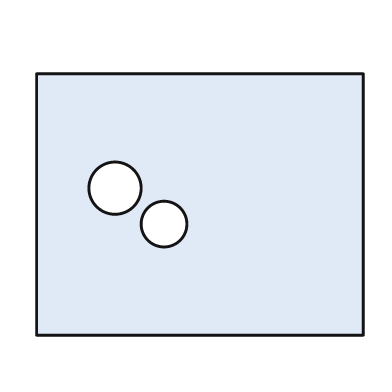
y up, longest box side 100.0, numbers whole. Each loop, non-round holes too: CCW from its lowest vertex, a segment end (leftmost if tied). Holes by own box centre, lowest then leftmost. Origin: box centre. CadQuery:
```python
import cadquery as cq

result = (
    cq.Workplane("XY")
    .moveTo(-50.0, -40.0)
    .lineTo(50.0, -40.0)
    .lineTo(50.0, 40.0)
    .lineTo(-50.0, 40.0)
    .close()
    .moveTo(-11.0, -6.0)
    .circle(7.0)
    .moveTo(-26.0, 5.0)
    .circle(8.0)
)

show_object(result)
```